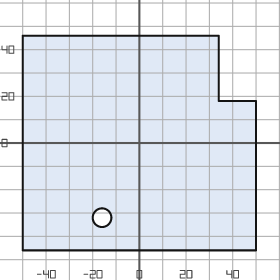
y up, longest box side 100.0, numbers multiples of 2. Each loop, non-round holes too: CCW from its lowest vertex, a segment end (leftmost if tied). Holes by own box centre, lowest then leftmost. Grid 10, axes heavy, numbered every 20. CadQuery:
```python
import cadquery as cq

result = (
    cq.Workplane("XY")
    .moveTo(-50.0, -46.0)
    .lineTo(50.0, -46.0)
    .lineTo(50.0, 18.0)
    .lineTo(34.0, 18.0)
    .lineTo(34.0, 46.0)
    .lineTo(-50.0, 46.0)
    .close()
    .moveTo(-16.0, -32.0)
    .circle(4.0)
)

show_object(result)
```